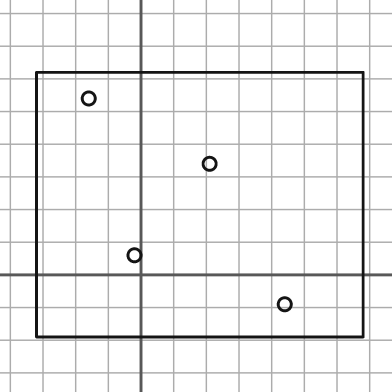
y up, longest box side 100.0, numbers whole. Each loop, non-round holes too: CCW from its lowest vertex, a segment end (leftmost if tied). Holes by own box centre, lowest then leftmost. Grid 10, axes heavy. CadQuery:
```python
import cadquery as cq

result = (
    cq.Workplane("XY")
    .moveTo(-32.0, -19.0)
    .lineTo(68.0, -19.0)
    .lineTo(68.0, 62.0)
    .lineTo(-32.0, 62.0)
    .close()
    .moveTo(44.0, -9.0)
    .circle(2.0)
    .moveTo(-2.0, 6.0)
    .circle(2.0)
    .moveTo(21.0, 34.0)
    .circle(2.0)
    .moveTo(-16.0, 54.0)
    .circle(2.0)
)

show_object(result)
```